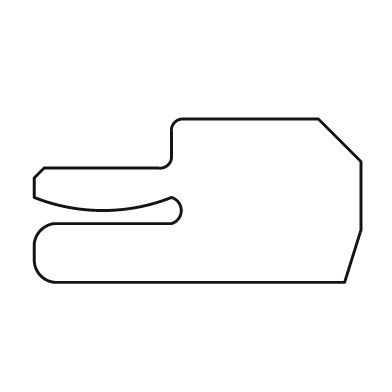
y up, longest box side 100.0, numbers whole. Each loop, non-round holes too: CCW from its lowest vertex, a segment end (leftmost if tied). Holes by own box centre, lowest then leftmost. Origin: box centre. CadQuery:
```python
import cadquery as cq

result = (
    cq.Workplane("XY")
    .moveTo(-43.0, -25.0)
    .lineTo(45.0, -25.0)
    .lineTo(50.0, -9.0)
    .lineTo(50.0, 12.0)
    .lineTo(37.0, 25.0)
    .lineTo(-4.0, 25.0)
    .threePointArc((-7.0, 24.0), (-8.0, 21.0))
    .lineTo(-8.0, 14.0)
    .threePointArc((-9.0, 11.0), (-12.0, 10.0))
    .lineTo(-47.0, 10.0)
    .lineTo(-50.0, 7.0)
    .lineTo(-50.0, 1.0)
    .threePointArc((-29.0, -3.0), (-8.0, 1.0))
    .threePointArc((-5.0, -3.0), (-8.0, -7.0))
    .lineTo(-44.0, -7.0)
    .threePointArc((-48.0, -9.0), (-50.0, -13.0))
    .lineTo(-50.0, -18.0)
    .threePointArc((-48.0, -23.0), (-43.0, -25.0))
    .close()
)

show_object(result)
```